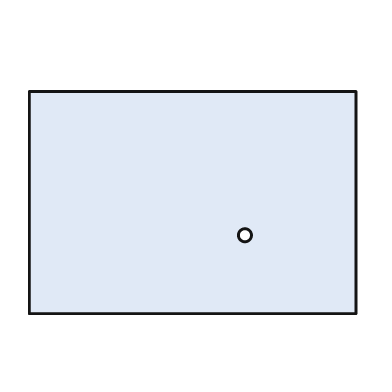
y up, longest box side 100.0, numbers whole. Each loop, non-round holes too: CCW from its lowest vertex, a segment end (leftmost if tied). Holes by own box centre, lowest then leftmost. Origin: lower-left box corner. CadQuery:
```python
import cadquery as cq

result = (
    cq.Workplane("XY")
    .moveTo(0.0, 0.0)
    .lineTo(100.0, 0.0)
    .lineTo(100.0, 68.0)
    .lineTo(0.0, 68.0)
    .close()
    .moveTo(66.0, 24.0)
    .circle(2.0)
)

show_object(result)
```